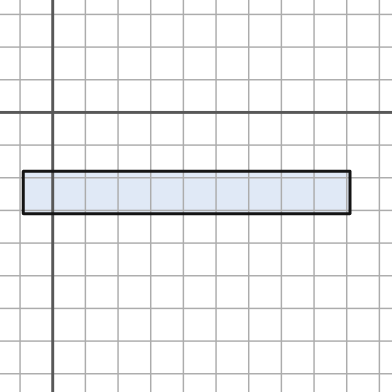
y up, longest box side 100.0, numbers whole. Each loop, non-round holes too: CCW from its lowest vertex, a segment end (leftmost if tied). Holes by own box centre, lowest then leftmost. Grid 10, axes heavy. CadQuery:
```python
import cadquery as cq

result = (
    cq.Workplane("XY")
    .moveTo(-9.0, -31.0)
    .lineTo(91.0, -31.0)
    .lineTo(91.0, -18.0)
    .lineTo(-9.0, -18.0)
    .close()
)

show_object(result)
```